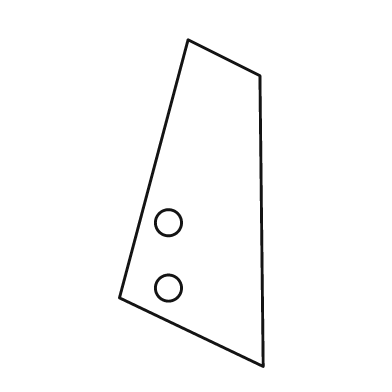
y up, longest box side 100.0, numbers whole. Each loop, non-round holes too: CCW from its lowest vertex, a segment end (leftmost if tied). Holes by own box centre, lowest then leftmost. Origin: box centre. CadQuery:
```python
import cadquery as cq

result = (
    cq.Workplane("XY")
    .moveTo(22.0, -50.0)
    .lineTo(21.0, 39.0)
    .lineTo(-1.0, 50.0)
    .lineTo(-22.0, -29.0)
    .close()
    .moveTo(-7.0, -26.0)
    .circle(4.0)
    .moveTo(-7.0, -6.0)
    .circle(4.0)
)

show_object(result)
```